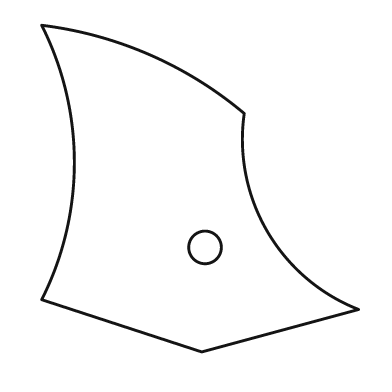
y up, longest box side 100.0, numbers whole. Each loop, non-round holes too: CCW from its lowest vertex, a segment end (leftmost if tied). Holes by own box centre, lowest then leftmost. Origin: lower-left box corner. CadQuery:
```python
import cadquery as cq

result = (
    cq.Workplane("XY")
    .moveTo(49.0, 0.0)
    .lineTo(97.0, 13.0)
    .threePointArc((69.0, 37.0), (62.0, 73.0))
    .threePointArc((33.0, 91.0), (0.0, 100.0))
    .threePointArc((10.0, 58.0), (0.0, 16.0))
    .close()
    .moveTo(50.0, 32.0)
    .circle(5.0)
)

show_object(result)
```